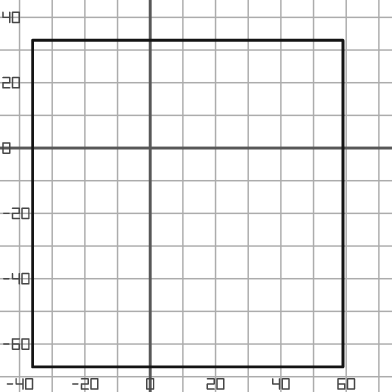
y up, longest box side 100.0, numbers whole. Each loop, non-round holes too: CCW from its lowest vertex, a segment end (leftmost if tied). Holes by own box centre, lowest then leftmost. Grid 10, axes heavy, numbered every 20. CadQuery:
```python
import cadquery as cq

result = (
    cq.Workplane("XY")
    .moveTo(-36.0, -67.0)
    .lineTo(59.0, -67.0)
    .lineTo(59.0, 33.0)
    .lineTo(-36.0, 33.0)
    .close()
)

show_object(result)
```